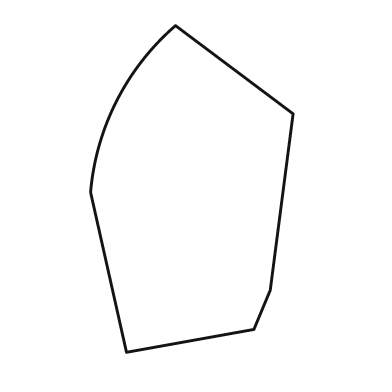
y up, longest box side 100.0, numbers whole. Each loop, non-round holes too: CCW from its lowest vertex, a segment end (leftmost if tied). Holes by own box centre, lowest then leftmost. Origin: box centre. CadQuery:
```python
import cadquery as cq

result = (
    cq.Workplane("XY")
    .moveTo(-20.0, -50.0)
    .lineTo(19.0, -43.0)
    .lineTo(24.0, -31.0)
    .lineTo(31.0, 23.0)
    .lineTo(-5.0, 50.0)
    .threePointArc((-23.0, 27.0), (-31.0, -1.0))
    .close()
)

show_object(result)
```